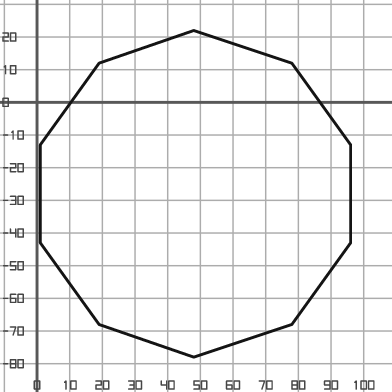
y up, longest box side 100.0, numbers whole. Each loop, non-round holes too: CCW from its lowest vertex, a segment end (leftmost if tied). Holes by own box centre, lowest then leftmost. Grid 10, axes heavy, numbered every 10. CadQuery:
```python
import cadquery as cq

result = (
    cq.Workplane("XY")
    .moveTo(48.0, -78.0)
    .lineTo(78.0, -68.0)
    .lineTo(96.0, -43.0)
    .lineTo(96.0, -13.0)
    .lineTo(78.0, 12.0)
    .lineTo(48.0, 22.0)
    .lineTo(19.0, 12.0)
    .lineTo(1.0, -13.0)
    .lineTo(1.0, -43.0)
    .lineTo(19.0, -68.0)
    .close()
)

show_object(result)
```